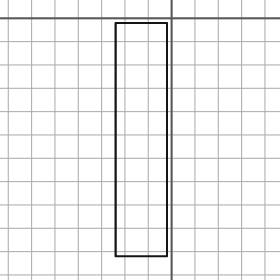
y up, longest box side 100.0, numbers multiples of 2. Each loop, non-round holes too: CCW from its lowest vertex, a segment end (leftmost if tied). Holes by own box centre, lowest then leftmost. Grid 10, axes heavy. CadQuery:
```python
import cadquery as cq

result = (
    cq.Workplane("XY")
    .moveTo(-24.0, -102.0)
    .lineTo(-2.0, -102.0)
    .lineTo(-2.0, -2.0)
    .lineTo(-24.0, -2.0)
    .close()
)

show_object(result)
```